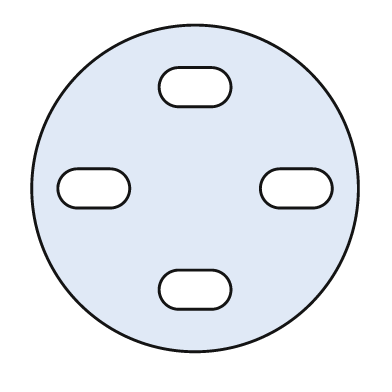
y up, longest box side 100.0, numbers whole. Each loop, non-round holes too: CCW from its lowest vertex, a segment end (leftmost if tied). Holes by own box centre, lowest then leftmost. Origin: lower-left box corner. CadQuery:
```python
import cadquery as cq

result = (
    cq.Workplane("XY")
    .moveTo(50.0, 50.0)
    .circle(50.0)
    .moveTo(45.0, 13.0)
    .lineTo(55.0, 13.0)
    .threePointArc((61.0, 19.0), (55.0, 25.0))
    .lineTo(45.0, 25.0)
    .threePointArc((39.0, 19.0), (45.0, 13.0))
    .close()
    .moveTo(14.0, 44.0)
    .lineTo(24.0, 44.0)
    .threePointArc((30.0, 50.0), (24.0, 56.0))
    .lineTo(14.0, 56.0)
    .threePointArc((8.0, 50.0), (14.0, 44.0))
    .close()
    .moveTo(76.0, 44.0)
    .lineTo(86.0, 44.0)
    .threePointArc((92.0, 50.0), (86.0, 56.0))
    .lineTo(76.0, 56.0)
    .threePointArc((70.0, 50.0), (76.0, 44.0))
    .close()
    .moveTo(45.0, 75.0)
    .lineTo(55.0, 75.0)
    .threePointArc((61.0, 81.0), (55.0, 87.0))
    .lineTo(45.0, 87.0)
    .threePointArc((39.0, 81.0), (45.0, 75.0))
    .close()
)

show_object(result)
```